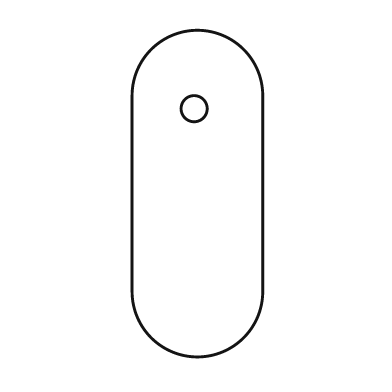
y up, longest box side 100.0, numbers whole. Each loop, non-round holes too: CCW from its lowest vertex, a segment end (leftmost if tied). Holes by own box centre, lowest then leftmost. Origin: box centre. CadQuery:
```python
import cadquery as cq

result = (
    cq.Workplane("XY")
    .moveTo(-20.0, -30.0)
    .threePointArc((0.0, -50.0), (20.0, -30.0))
    .lineTo(20.0, 30.0)
    .threePointArc((0.0, 50.0), (-20.0, 30.0))
    .close()
    .moveTo(-1.0, 26.0)
    .circle(4.0)
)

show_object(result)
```